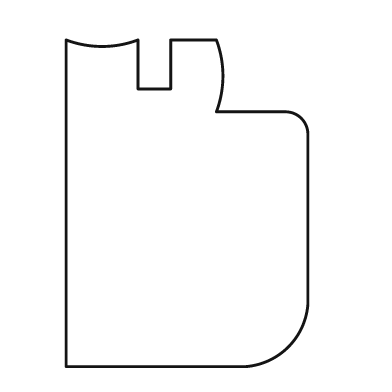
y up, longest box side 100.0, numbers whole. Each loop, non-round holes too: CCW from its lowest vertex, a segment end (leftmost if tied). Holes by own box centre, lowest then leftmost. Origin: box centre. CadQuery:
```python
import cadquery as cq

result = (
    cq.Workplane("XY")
    .moveTo(-37.0, -50.0)
    .lineTo(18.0, -50.0)
    .threePointArc((31.0, -44.0), (37.0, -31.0))
    .lineTo(37.0, 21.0)
    .threePointArc((35.0, 26.0), (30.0, 28.0))
    .lineTo(9.0, 28.0)
    .threePointArc((11.0, 39.0), (9.0, 50.0))
    .lineTo(-5.0, 50.0)
    .lineTo(-5.0, 35.0)
    .lineTo(-15.0, 35.0)
    .lineTo(-15.0, 50.0)
    .threePointArc((-26.0, 48.0), (-37.0, 50.0))
    .close()
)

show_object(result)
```